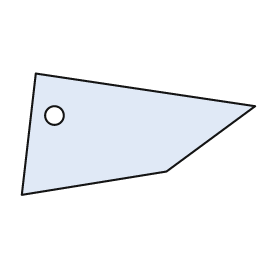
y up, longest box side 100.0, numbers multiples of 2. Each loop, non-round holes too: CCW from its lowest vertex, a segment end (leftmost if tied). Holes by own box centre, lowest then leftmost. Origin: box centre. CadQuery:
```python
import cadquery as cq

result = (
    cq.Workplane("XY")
    .moveTo(-50.0, -26.0)
    .lineTo(12.0, -16.0)
    .lineTo(50.0, 12.0)
    .lineTo(-44.0, 26.0)
    .close()
    .moveTo(-36.0, 8.0)
    .circle(4.0)
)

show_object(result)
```